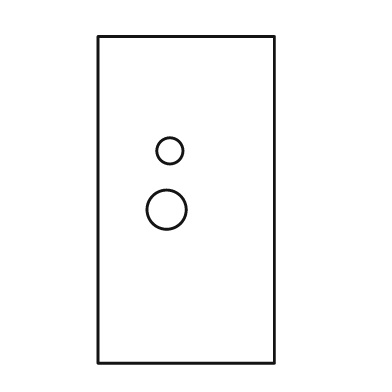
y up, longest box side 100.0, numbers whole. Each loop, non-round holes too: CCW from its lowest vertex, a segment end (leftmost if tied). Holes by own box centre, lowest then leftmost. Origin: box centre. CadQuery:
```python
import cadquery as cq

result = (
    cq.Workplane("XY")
    .moveTo(-27.0, -50.0)
    .lineTo(27.0, -50.0)
    .lineTo(27.0, 50.0)
    .lineTo(-27.0, 50.0)
    .close()
    .moveTo(-6.0, -3.0)
    .circle(6.0)
    .moveTo(-5.0, 15.0)
    .circle(4.0)
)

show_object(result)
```